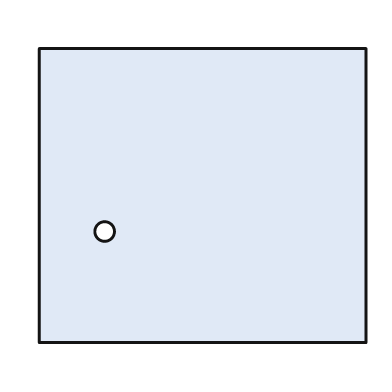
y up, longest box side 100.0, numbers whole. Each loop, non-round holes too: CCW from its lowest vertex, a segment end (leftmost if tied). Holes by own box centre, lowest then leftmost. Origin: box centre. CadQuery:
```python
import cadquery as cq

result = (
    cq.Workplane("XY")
    .moveTo(-50.0, -45.0)
    .lineTo(50.0, -45.0)
    .lineTo(50.0, 45.0)
    .lineTo(-50.0, 45.0)
    .close()
    .moveTo(-30.0, -11.0)
    .circle(3.0)
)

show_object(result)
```